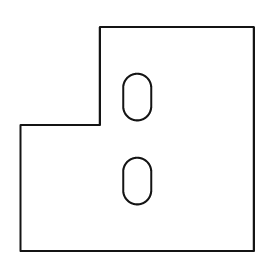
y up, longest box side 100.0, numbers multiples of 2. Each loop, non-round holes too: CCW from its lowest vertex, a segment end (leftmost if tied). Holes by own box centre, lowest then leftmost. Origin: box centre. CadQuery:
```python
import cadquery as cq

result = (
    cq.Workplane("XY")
    .moveTo(-50.0, -48.0)
    .lineTo(50.0, -48.0)
    .lineTo(50.0, 48.0)
    .lineTo(-16.0, 48.0)
    .lineTo(-16.0, 6.0)
    .lineTo(-50.0, 6.0)
    .close()
    .moveTo(-6.0, -22.0)
    .threePointArc((0.0, -28.0), (6.0, -22.0))
    .lineTo(6.0, -14.0)
    .threePointArc((0.0, -8.0), (-6.0, -14.0))
    .close()
    .moveTo(-6.0, 14.0)
    .threePointArc((0.0, 8.0), (6.0, 14.0))
    .lineTo(6.0, 22.0)
    .threePointArc((0.0, 28.0), (-6.0, 22.0))
    .close()
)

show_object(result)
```